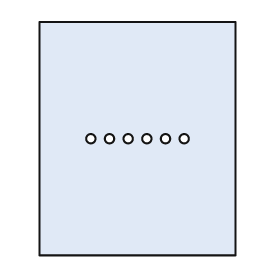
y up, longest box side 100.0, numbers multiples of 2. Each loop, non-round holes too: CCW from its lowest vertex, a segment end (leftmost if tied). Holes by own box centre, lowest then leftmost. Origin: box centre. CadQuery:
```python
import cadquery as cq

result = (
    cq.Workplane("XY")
    .moveTo(-42.0, -50.0)
    .lineTo(42.0, -50.0)
    .lineTo(42.0, 50.0)
    .lineTo(-42.0, 50.0)
    .close()
    .moveTo(-20.0, 0.0)
    .circle(2.0)
    .moveTo(-12.0, 0.0)
    .circle(2.0)
    .moveTo(-4.0, 0.0)
    .circle(2.0)
    .moveTo(4.0, 0.0)
    .circle(2.0)
    .moveTo(12.0, 0.0)
    .circle(2.0)
    .moveTo(20.0, 0.0)
    .circle(2.0)
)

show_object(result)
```